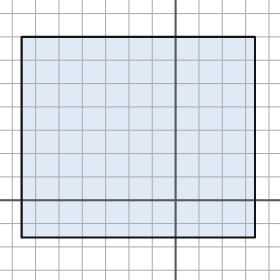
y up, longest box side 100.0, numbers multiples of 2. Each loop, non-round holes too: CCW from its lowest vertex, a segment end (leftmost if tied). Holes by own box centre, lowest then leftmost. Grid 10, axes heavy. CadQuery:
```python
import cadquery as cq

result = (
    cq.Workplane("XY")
    .moveTo(-66.0, -16.0)
    .lineTo(34.0, -16.0)
    .lineTo(34.0, 70.0)
    .lineTo(-66.0, 70.0)
    .close()
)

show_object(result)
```